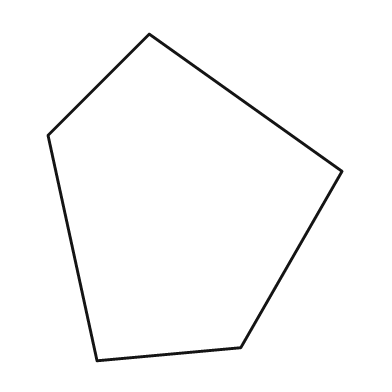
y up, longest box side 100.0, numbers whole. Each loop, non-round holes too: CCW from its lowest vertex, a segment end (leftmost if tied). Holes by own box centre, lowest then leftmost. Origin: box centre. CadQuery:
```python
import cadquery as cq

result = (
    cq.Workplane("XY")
    .moveTo(-30.0, -50.0)
    .lineTo(14.0, -46.0)
    .lineTo(45.0, 8.0)
    .lineTo(-14.0, 50.0)
    .lineTo(-45.0, 19.0)
    .close()
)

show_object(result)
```